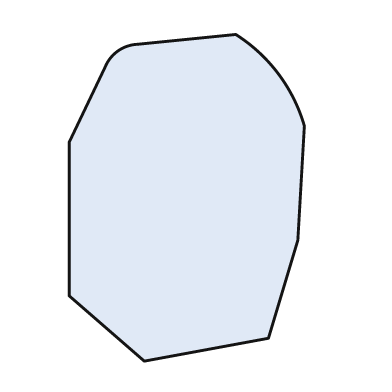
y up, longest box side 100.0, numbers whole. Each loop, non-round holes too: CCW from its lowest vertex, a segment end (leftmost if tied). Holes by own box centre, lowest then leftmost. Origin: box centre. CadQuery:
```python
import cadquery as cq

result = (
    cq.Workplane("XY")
    .moveTo(-13.0, -50.0)
    .lineTo(25.0, -43.0)
    .lineTo(34.0, -13.0)
    .lineTo(36.0, 22.0)
    .threePointArc((28.0, 38.0), (15.0, 50.0))
    .lineTo(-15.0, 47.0)
    .threePointArc((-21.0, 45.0), (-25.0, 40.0))
    .lineTo(-36.0, 17.0)
    .lineTo(-36.0, -30.0)
    .close()
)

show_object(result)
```